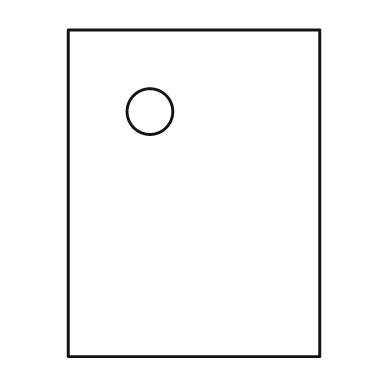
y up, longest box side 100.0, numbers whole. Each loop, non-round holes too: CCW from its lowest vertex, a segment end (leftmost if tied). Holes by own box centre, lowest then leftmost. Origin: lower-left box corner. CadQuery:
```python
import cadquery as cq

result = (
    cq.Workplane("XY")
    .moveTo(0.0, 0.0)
    .lineTo(77.0, 0.0)
    .lineTo(77.0, 100.0)
    .lineTo(0.0, 100.0)
    .close()
    .moveTo(25.0, 75.0)
    .circle(7.0)
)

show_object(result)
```